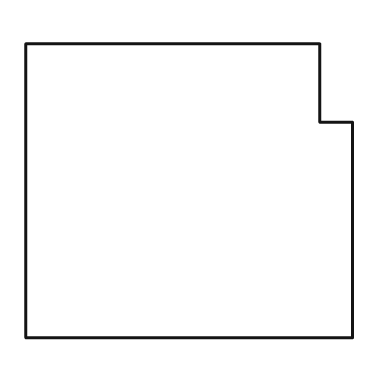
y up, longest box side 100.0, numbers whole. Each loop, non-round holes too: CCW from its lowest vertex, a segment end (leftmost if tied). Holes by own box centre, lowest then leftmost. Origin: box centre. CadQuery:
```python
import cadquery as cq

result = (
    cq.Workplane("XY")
    .moveTo(-50.0, -45.0)
    .lineTo(50.0, -45.0)
    .lineTo(50.0, 21.0)
    .lineTo(40.0, 21.0)
    .lineTo(40.0, 45.0)
    .lineTo(-50.0, 45.0)
    .close()
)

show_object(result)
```